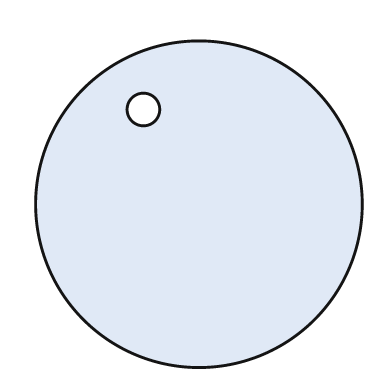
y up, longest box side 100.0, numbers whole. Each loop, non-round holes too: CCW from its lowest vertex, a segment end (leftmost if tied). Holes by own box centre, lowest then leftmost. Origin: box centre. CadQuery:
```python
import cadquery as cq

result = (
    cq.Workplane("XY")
    .moveTo(0.0, 0.0)
    .circle(50.0)
    .moveTo(-17.0, 29.0)
    .circle(5.0)
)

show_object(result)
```